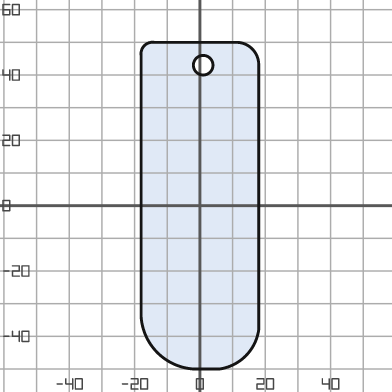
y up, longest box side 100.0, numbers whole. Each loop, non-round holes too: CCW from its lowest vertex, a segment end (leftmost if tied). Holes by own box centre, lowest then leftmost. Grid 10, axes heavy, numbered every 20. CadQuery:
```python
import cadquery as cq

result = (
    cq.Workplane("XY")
    .moveTo(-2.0, -50.0)
    .lineTo(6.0, -50.0)
    .threePointArc((14.0, -46.0), (18.0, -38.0))
    .lineTo(18.0, 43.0)
    .threePointArc((16.0, 48.0), (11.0, 50.0))
    .lineTo(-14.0, 50.0)
    .threePointArc((-17.0, 49.0), (-18.0, 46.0))
    .lineTo(-18.0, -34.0)
    .threePointArc((-13.0, -45.0), (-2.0, -50.0))
    .close()
    .moveTo(1.0, 43.0)
    .circle(3.0)
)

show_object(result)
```